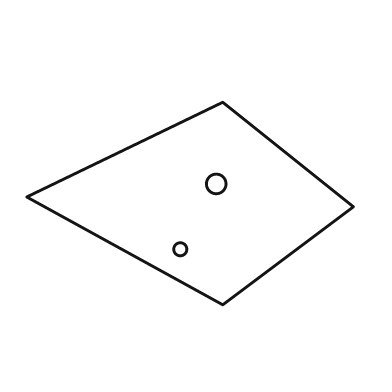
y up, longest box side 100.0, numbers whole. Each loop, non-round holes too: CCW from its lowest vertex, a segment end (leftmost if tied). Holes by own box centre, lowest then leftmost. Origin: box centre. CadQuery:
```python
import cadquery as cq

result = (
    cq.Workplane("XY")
    .moveTo(10.0, -31.0)
    .lineTo(50.0, -1.0)
    .lineTo(10.0, 31.0)
    .lineTo(-50.0, 2.0)
    .close()
    .moveTo(-3.0, -14.0)
    .circle(2.0)
    .moveTo(8.0, 6.0)
    .circle(3.0)
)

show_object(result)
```